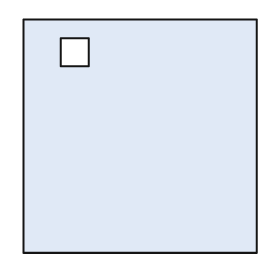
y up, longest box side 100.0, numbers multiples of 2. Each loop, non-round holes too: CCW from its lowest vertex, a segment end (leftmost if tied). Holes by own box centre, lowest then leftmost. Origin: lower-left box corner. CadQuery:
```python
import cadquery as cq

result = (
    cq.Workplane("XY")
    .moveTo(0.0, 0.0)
    .lineTo(100.0, 0.0)
    .lineTo(100.0, 100.0)
    .lineTo(0.0, 100.0)
    .close()
    .moveTo(16.0, 80.0)
    .lineTo(28.0, 80.0)
    .lineTo(28.0, 92.0)
    .lineTo(16.0, 92.0)
    .close()
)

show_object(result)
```